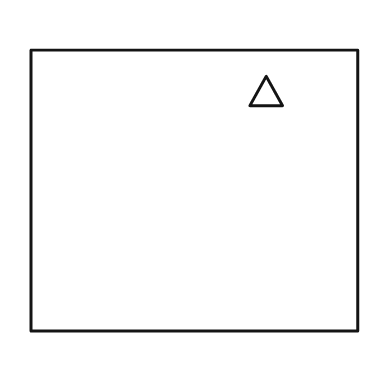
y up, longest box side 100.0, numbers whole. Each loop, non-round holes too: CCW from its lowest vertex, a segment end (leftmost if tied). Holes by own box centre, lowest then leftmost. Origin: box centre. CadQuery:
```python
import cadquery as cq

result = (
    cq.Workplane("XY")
    .moveTo(-50.0, -43.0)
    .lineTo(50.0, -43.0)
    .lineTo(50.0, 43.0)
    .lineTo(-50.0, 43.0)
    .close()
    .moveTo(17.0, 26.0)
    .lineTo(27.0, 26.0)
    .lineTo(22.0, 35.0)
    .close()
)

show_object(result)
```